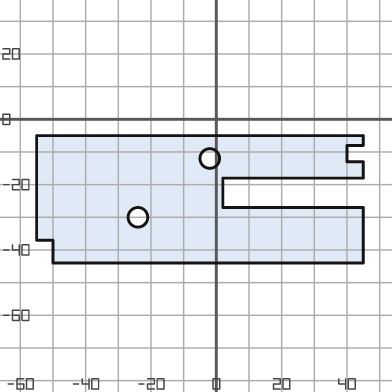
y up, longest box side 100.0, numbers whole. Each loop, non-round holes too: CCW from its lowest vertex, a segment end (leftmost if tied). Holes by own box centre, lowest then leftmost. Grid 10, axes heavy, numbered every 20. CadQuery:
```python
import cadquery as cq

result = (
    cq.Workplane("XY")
    .moveTo(-50.0, -44.0)
    .lineTo(45.0, -44.0)
    .lineTo(45.0, -27.0)
    .lineTo(2.0, -27.0)
    .lineTo(2.0, -18.0)
    .lineTo(45.0, -18.0)
    .lineTo(45.0, -13.0)
    .lineTo(40.0, -13.0)
    .lineTo(40.0, -8.0)
    .lineTo(45.0, -8.0)
    .lineTo(45.0, -5.0)
    .lineTo(-55.0, -5.0)
    .lineTo(-55.0, -37.0)
    .lineTo(-50.0, -37.0)
    .close()
    .moveTo(-24.0, -30.0)
    .circle(3.0)
    .moveTo(-2.0, -12.0)
    .circle(3.0)
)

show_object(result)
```